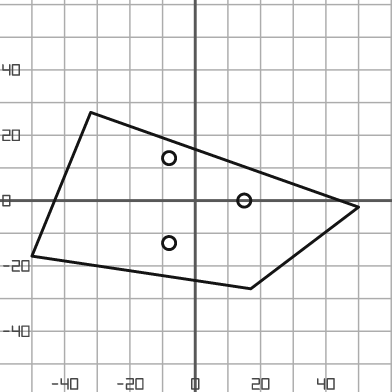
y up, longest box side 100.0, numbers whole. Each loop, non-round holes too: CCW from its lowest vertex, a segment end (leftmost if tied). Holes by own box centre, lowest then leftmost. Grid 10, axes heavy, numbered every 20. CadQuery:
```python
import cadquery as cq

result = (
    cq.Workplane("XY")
    .moveTo(17.0, -27.0)
    .lineTo(50.0, -2.0)
    .lineTo(-32.0, 27.0)
    .lineTo(-50.0, -17.0)
    .close()
    .moveTo(-8.0, -13.0)
    .circle(2.0)
    .moveTo(15.0, 0.0)
    .circle(2.0)
    .moveTo(-8.0, 13.0)
    .circle(2.0)
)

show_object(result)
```